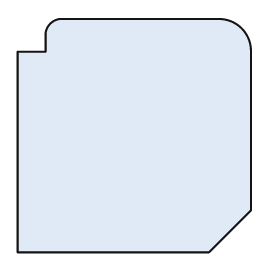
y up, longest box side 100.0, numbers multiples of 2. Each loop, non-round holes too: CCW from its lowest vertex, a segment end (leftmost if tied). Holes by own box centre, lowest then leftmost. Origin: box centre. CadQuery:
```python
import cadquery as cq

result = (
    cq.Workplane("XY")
    .moveTo(-50.0, -50.0)
    .lineTo(32.0, -50.0)
    .lineTo(50.0, -32.0)
    .lineTo(50.0, 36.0)
    .threePointArc((46.0, 46.0), (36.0, 50.0))
    .lineTo(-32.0, 50.0)
    .threePointArc((-36.0, 48.0), (-38.0, 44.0))
    .lineTo(-38.0, 36.0)
    .lineTo(-50.0, 36.0)
    .close()
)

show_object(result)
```